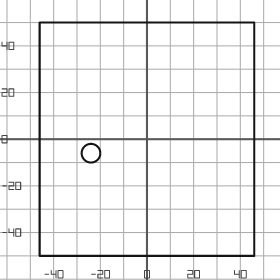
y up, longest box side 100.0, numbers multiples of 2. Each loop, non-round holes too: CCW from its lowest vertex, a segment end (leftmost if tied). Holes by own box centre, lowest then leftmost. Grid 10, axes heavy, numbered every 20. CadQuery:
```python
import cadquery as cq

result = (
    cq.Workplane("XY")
    .moveTo(-46.0, -50.0)
    .lineTo(46.0, -50.0)
    .lineTo(46.0, 50.0)
    .lineTo(-46.0, 50.0)
    .close()
    .moveTo(-24.0, -6.0)
    .circle(4.0)
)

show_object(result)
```